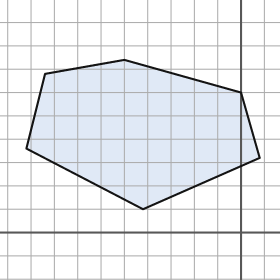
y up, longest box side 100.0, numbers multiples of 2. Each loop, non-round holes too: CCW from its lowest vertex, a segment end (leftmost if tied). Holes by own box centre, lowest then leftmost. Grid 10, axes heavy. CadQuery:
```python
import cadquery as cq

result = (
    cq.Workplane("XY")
    .moveTo(-42.0, 10.0)
    .lineTo(8.0, 32.0)
    .lineTo(0.0, 60.0)
    .lineTo(-50.0, 74.0)
    .lineTo(-84.0, 68.0)
    .lineTo(-92.0, 36.0)
    .close()
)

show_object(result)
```